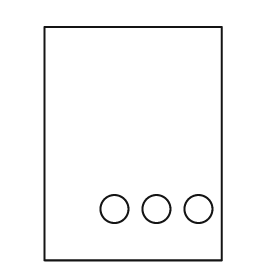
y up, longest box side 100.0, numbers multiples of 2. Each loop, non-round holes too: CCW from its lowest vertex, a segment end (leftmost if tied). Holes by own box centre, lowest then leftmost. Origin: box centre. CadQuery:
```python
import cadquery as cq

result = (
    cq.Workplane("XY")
    .moveTo(-38.0, -50.0)
    .lineTo(38.0, -50.0)
    .lineTo(38.0, 50.0)
    .lineTo(-38.0, 50.0)
    .close()
    .moveTo(-8.0, -28.0)
    .circle(6.0)
    .moveTo(10.0, -28.0)
    .circle(6.0)
    .moveTo(28.0, -28.0)
    .circle(6.0)
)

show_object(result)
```